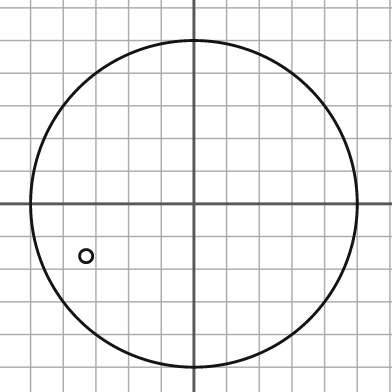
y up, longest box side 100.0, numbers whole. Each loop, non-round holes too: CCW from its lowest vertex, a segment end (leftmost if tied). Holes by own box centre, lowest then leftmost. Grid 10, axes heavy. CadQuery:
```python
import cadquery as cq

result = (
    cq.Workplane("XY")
    .moveTo(0.0, 0.0)
    .circle(50.0)
    .moveTo(-33.0, -16.0)
    .circle(2.0)
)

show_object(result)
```